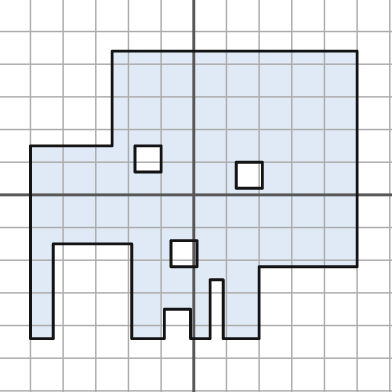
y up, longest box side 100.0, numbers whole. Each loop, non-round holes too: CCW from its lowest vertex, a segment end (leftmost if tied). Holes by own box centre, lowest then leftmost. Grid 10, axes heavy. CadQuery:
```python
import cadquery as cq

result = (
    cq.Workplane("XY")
    .moveTo(-50.0, -44.0)
    .lineTo(-43.0, -44.0)
    .lineTo(-43.0, -15.0)
    .lineTo(-19.0, -15.0)
    .lineTo(-19.0, -44.0)
    .lineTo(-9.0, -44.0)
    .lineTo(-9.0, -35.0)
    .lineTo(-1.0, -35.0)
    .lineTo(-1.0, -44.0)
    .lineTo(5.0, -44.0)
    .lineTo(5.0, -26.0)
    .lineTo(9.0, -26.0)
    .lineTo(9.0, -44.0)
    .lineTo(20.0, -44.0)
    .lineTo(20.0, -22.0)
    .lineTo(50.0, -22.0)
    .lineTo(50.0, 44.0)
    .lineTo(-25.0, 44.0)
    .lineTo(-25.0, 15.0)
    .lineTo(-50.0, 15.0)
    .close()
    .moveTo(-7.0, -22.0)
    .lineTo(1.0, -22.0)
    .lineTo(1.0, -14.0)
    .lineTo(-7.0, -14.0)
    .close()
    .moveTo(13.0, 2.0)
    .lineTo(21.0, 2.0)
    .lineTo(21.0, 10.0)
    .lineTo(13.0, 10.0)
    .close()
    .moveTo(-18.0, 7.0)
    .lineTo(-10.0, 7.0)
    .lineTo(-10.0, 15.0)
    .lineTo(-18.0, 15.0)
    .close()
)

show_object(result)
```